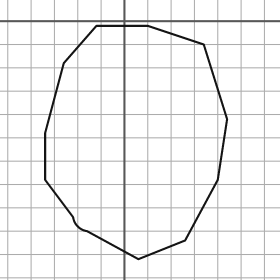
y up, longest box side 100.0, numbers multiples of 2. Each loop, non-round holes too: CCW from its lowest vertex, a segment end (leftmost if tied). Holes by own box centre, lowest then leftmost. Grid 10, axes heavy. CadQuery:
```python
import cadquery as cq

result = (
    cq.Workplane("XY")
    .moveTo(6.0, -102.0)
    .lineTo(26.0, -94.0)
    .lineTo(40.0, -68.0)
    .lineTo(44.0, -42.0)
    .lineTo(34.0, -10.0)
    .lineTo(10.0, -2.0)
    .lineTo(-12.0, -2.0)
    .lineTo(-26.0, -18.0)
    .lineTo(-34.0, -48.0)
    .lineTo(-34.0, -68.0)
    .lineTo(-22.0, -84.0)
    .threePointArc((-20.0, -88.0), (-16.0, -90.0))
    .close()
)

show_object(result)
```